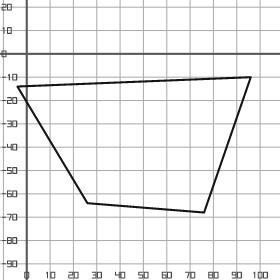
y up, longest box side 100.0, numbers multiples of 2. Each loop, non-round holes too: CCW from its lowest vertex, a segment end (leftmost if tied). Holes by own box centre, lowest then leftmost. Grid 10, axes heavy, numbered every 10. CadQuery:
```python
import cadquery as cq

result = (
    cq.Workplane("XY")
    .moveTo(76.0, -68.0)
    .lineTo(96.0, -10.0)
    .lineTo(-4.0, -14.0)
    .lineTo(26.0, -64.0)
    .close()
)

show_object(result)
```